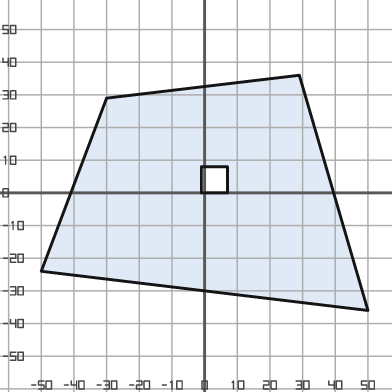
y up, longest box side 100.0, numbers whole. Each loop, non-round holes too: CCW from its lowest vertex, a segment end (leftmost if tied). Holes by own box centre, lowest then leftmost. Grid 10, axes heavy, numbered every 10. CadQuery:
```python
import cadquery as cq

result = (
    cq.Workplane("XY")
    .moveTo(50.0, -36.0)
    .lineTo(29.0, 36.0)
    .lineTo(-30.0, 29.0)
    .lineTo(-50.0, -24.0)
    .close()
    .moveTo(-1.0, 0.0)
    .lineTo(7.0, 0.0)
    .lineTo(7.0, 8.0)
    .lineTo(-1.0, 8.0)
    .close()
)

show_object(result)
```